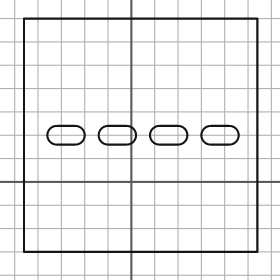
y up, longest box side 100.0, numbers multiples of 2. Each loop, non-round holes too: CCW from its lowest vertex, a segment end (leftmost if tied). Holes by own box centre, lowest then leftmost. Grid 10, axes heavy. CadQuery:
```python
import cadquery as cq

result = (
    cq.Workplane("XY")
    .moveTo(-46.0, -30.0)
    .lineTo(54.0, -30.0)
    .lineTo(54.0, 70.0)
    .lineTo(-46.0, 70.0)
    .close()
    .moveTo(-32.0, 16.0)
    .lineTo(-24.0, 16.0)
    .threePointArc((-20.0, 20.0), (-24.0, 24.0))
    .lineTo(-32.0, 24.0)
    .threePointArc((-36.0, 20.0), (-32.0, 16.0))
    .close()
    .moveTo(-10.0, 16.0)
    .lineTo(-2.0, 16.0)
    .threePointArc((2.0, 20.0), (-2.0, 24.0))
    .lineTo(-10.0, 24.0)
    .threePointArc((-14.0, 20.0), (-10.0, 16.0))
    .close()
    .moveTo(12.0, 16.0)
    .lineTo(20.0, 16.0)
    .threePointArc((24.0, 20.0), (20.0, 24.0))
    .lineTo(12.0, 24.0)
    .threePointArc((8.0, 20.0), (12.0, 16.0))
    .close()
    .moveTo(34.0, 16.0)
    .lineTo(42.0, 16.0)
    .threePointArc((46.0, 20.0), (42.0, 24.0))
    .lineTo(34.0, 24.0)
    .threePointArc((30.0, 20.0), (34.0, 16.0))
    .close()
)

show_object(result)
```